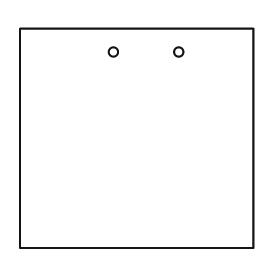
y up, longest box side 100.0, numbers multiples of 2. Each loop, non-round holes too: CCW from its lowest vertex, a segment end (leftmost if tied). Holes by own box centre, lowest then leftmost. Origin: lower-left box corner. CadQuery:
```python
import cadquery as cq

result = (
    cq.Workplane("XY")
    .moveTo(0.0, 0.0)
    .lineTo(100.0, 0.0)
    .lineTo(100.0, 94.0)
    .lineTo(0.0, 94.0)
    .close()
    .moveTo(40.0, 84.0)
    .circle(2.0)
    .moveTo(68.0, 84.0)
    .circle(2.0)
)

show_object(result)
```